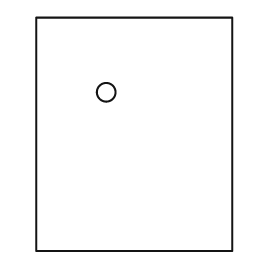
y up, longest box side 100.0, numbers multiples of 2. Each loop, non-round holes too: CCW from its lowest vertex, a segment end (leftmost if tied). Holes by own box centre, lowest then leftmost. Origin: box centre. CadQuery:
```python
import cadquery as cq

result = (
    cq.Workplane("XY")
    .moveTo(-42.0, -50.0)
    .lineTo(42.0, -50.0)
    .lineTo(42.0, 50.0)
    .lineTo(-42.0, 50.0)
    .close()
    .moveTo(-12.0, 18.0)
    .circle(4.0)
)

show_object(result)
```